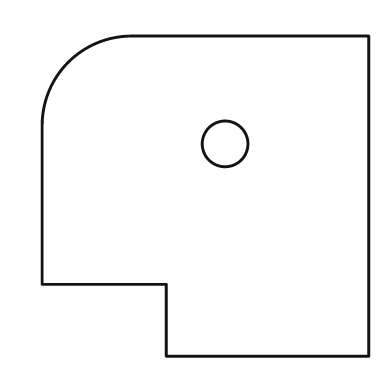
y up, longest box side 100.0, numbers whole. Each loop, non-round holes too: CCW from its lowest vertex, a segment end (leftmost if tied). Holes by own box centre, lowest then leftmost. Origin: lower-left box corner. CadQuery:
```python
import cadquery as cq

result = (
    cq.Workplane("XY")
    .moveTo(38.0, 0.0)
    .lineTo(100.0, 0.0)
    .lineTo(100.0, 98.0)
    .lineTo(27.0, 98.0)
    .threePointArc((8.0, 90.0), (0.0, 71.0))
    .lineTo(0.0, 22.0)
    .lineTo(38.0, 22.0)
    .close()
    .moveTo(56.0, 65.0)
    .circle(7.0)
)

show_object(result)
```